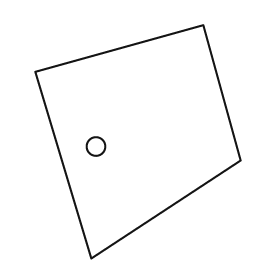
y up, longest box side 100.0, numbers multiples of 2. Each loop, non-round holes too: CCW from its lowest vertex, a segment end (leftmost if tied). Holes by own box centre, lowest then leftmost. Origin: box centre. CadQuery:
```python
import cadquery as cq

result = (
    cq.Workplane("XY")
    .moveTo(-20.0, -50.0)
    .lineTo(44.0, -8.0)
    .lineTo(28.0, 50.0)
    .lineTo(-44.0, 30.0)
    .close()
    .moveTo(-18.0, -2.0)
    .circle(4.0)
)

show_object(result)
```